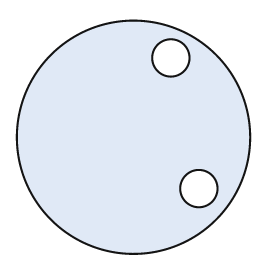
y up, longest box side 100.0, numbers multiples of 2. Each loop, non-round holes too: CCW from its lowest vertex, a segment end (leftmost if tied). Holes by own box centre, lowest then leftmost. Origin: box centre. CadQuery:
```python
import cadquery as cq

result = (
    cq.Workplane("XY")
    .moveTo(0.0, 0.0)
    .circle(50.0)
    .moveTo(28.0, -22.0)
    .circle(8.0)
    .moveTo(16.0, 34.0)
    .circle(8.0)
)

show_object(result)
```